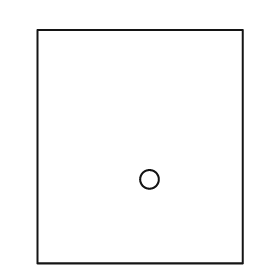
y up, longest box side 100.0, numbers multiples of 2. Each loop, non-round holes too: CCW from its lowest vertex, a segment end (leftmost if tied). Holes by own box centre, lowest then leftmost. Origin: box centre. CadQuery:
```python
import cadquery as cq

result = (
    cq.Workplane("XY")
    .moveTo(-44.0, -50.0)
    .lineTo(44.0, -50.0)
    .lineTo(44.0, 50.0)
    .lineTo(-44.0, 50.0)
    .close()
    .moveTo(4.0, -14.0)
    .circle(4.0)
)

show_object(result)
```